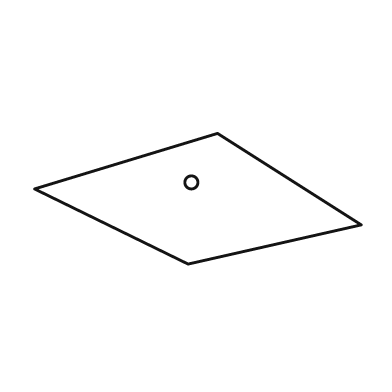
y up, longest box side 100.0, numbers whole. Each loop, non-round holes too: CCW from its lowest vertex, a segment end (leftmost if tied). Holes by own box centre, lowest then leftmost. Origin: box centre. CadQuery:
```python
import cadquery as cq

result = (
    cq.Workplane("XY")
    .moveTo(-3.0, -20.0)
    .lineTo(50.0, -8.0)
    .lineTo(6.0, 20.0)
    .lineTo(-50.0, 3.0)
    .close()
    .moveTo(-2.0, 5.0)
    .circle(2.0)
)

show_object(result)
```